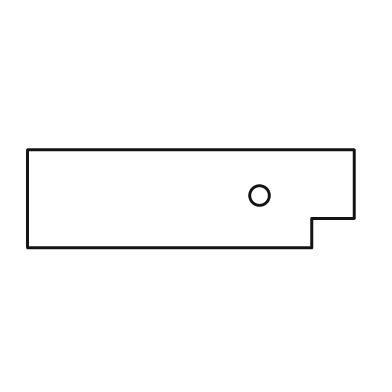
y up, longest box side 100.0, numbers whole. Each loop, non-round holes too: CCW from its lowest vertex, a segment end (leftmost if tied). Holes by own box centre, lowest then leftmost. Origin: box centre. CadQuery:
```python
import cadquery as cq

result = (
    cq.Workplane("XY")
    .moveTo(-50.0, -15.0)
    .lineTo(37.0, -15.0)
    .lineTo(37.0, -6.0)
    .lineTo(50.0, -6.0)
    .lineTo(50.0, 15.0)
    .lineTo(-50.0, 15.0)
    .close()
    .moveTo(21.0, 1.0)
    .circle(3.0)
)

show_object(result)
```